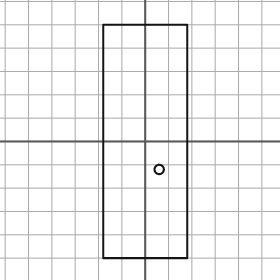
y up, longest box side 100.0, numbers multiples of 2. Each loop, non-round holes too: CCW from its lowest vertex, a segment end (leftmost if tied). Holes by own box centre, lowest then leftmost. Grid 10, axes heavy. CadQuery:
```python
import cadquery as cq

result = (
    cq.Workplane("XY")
    .moveTo(-18.0, -50.0)
    .lineTo(18.0, -50.0)
    .lineTo(18.0, 50.0)
    .lineTo(-18.0, 50.0)
    .close()
    .moveTo(6.0, -12.0)
    .circle(2.0)
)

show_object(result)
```